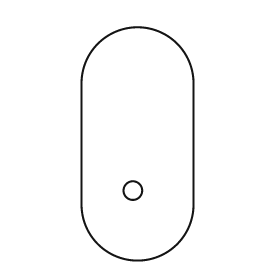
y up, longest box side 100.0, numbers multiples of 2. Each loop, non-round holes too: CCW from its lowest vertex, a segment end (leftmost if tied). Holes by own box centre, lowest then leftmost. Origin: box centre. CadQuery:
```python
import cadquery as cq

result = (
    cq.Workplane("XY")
    .moveTo(-24.0, -26.0)
    .threePointArc((0.0, -50.0), (24.0, -26.0))
    .lineTo(24.0, 26.0)
    .threePointArc((0.0, 50.0), (-24.0, 26.0))
    .close()
    .moveTo(-2.0, -20.0)
    .circle(4.0)
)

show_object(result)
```